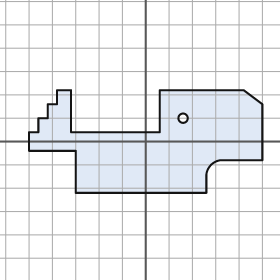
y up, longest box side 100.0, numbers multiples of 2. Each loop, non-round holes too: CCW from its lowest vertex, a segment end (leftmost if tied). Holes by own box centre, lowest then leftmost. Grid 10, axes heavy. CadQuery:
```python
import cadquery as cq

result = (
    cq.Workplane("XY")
    .moveTo(-30.0, -22.0)
    .lineTo(26.0, -22.0)
    .lineTo(26.0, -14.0)
    .threePointArc((28.0, -10.0), (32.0, -8.0))
    .lineTo(50.0, -8.0)
    .lineTo(50.0, 16.0)
    .lineTo(42.0, 22.0)
    .lineTo(6.0, 22.0)
    .lineTo(6.0, 4.0)
    .lineTo(-32.0, 4.0)
    .lineTo(-32.0, 22.0)
    .lineTo(-38.0, 22.0)
    .lineTo(-38.0, 16.0)
    .lineTo(-42.0, 16.0)
    .lineTo(-42.0, 10.0)
    .lineTo(-46.0, 10.0)
    .lineTo(-46.0, 4.0)
    .lineTo(-50.0, 4.0)
    .lineTo(-50.0, -4.0)
    .lineTo(-30.0, -4.0)
    .close()
    .moveTo(16.0, 10.0)
    .circle(2.0)
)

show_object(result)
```